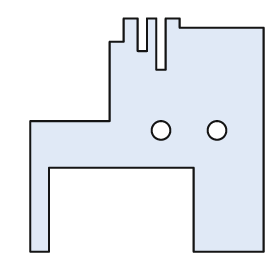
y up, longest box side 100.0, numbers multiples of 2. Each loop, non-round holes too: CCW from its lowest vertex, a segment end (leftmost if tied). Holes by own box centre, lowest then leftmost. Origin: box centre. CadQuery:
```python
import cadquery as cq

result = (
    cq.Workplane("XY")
    .moveTo(-50.0, -50.0)
    .lineTo(-42.0, -50.0)
    .lineTo(-42.0, -14.0)
    .lineTo(20.0, -14.0)
    .lineTo(20.0, -50.0)
    .lineTo(50.0, -50.0)
    .lineTo(50.0, 46.0)
    .lineTo(14.0, 46.0)
    .lineTo(14.0, 50.0)
    .lineTo(8.0, 50.0)
    .lineTo(8.0, 28.0)
    .lineTo(4.0, 28.0)
    .lineTo(4.0, 50.0)
    .lineTo(0.0, 50.0)
    .lineTo(0.0, 36.0)
    .lineTo(-4.0, 36.0)
    .lineTo(-4.0, 50.0)
    .lineTo(-10.0, 50.0)
    .lineTo(-10.0, 40.0)
    .lineTo(-16.0, 40.0)
    .lineTo(-16.0, 6.0)
    .lineTo(-50.0, 6.0)
    .close()
    .moveTo(6.0, 2.0)
    .circle(4.0)
    .moveTo(30.0, 2.0)
    .circle(4.0)
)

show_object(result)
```